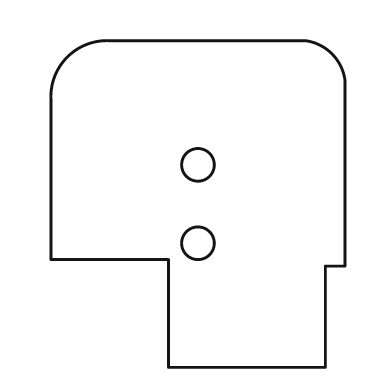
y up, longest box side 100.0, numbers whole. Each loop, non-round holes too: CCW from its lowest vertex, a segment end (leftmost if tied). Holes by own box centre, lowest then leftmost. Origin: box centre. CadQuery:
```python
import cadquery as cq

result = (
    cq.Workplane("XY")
    .moveTo(-9.0, -50.0)
    .lineTo(39.0, -50.0)
    .lineTo(39.0, -19.0)
    .lineTo(45.0, -19.0)
    .lineTo(45.0, 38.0)
    .threePointArc((41.0, 46.0), (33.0, 50.0))
    .lineTo(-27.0, 50.0)
    .threePointArc((-40.0, 45.0), (-45.0, 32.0))
    .lineTo(-45.0, -17.0)
    .lineTo(-9.0, -17.0)
    .close()
    .moveTo(0.0, -12.0)
    .circle(5.0)
    .moveTo(0.0, 12.0)
    .circle(5.0)
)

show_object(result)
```